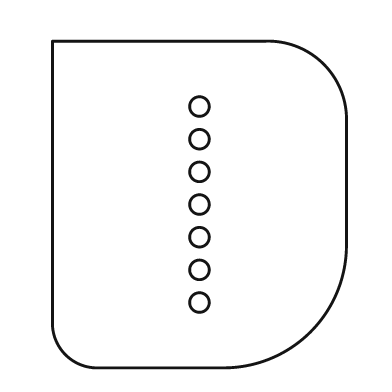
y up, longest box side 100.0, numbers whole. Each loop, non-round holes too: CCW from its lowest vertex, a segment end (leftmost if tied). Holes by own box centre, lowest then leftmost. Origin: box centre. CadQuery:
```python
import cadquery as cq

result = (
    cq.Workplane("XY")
    .moveTo(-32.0, -50.0)
    .lineTo(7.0, -50.0)
    .threePointArc((34.0, -39.0), (45.0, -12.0))
    .lineTo(45.0, 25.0)
    .threePointArc((38.0, 43.0), (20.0, 50.0))
    .lineTo(-45.0, 50.0)
    .lineTo(-45.0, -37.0)
    .threePointArc((-41.0, -46.0), (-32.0, -50.0))
    .close()
    .moveTo(0.0, -30.0)
    .circle(3.0)
    .moveTo(0.0, -20.0)
    .circle(3.0)
    .moveTo(0.0, -10.0)
    .circle(3.0)
    .moveTo(0.0, 0.0)
    .circle(3.0)
    .moveTo(0.0, 10.0)
    .circle(3.0)
    .moveTo(0.0, 20.0)
    .circle(3.0)
    .moveTo(0.0, 30.0)
    .circle(3.0)
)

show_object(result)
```